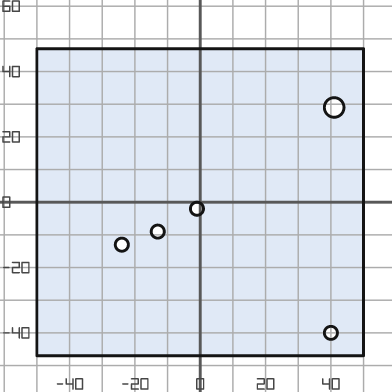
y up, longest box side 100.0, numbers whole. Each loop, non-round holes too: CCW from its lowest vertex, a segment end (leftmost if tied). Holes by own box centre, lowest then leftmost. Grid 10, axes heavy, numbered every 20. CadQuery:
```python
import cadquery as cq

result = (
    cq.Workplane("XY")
    .moveTo(-50.0, -47.0)
    .lineTo(50.0, -47.0)
    .lineTo(50.0, 47.0)
    .lineTo(-50.0, 47.0)
    .close()
    .moveTo(40.0, -40.0)
    .circle(2.0)
    .moveTo(-24.0, -13.0)
    .circle(2.0)
    .moveTo(-13.0, -9.0)
    .circle(2.0)
    .moveTo(-1.0, -2.0)
    .circle(2.0)
    .moveTo(41.0, 29.0)
    .circle(3.0)
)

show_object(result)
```